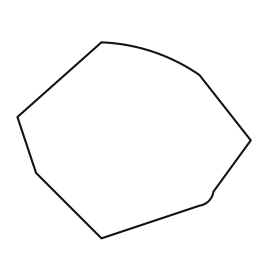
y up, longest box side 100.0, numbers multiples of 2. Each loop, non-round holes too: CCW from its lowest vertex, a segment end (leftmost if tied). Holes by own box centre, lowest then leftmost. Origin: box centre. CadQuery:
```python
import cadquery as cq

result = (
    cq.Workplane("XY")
    .moveTo(-14.0, -42.0)
    .lineTo(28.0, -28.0)
    .threePointArc((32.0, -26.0), (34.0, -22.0))
    .lineTo(50.0, 0.0)
    .lineTo(28.0, 28.0)
    .threePointArc((8.0, 38.0), (-14.0, 42.0))
    .lineTo(-50.0, 10.0)
    .lineTo(-42.0, -14.0)
    .close()
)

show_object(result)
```